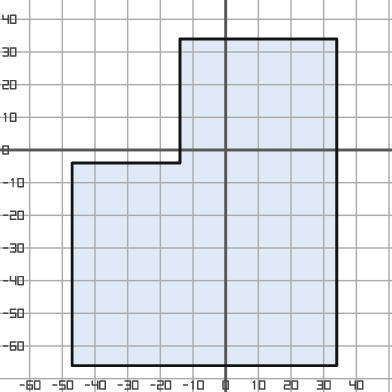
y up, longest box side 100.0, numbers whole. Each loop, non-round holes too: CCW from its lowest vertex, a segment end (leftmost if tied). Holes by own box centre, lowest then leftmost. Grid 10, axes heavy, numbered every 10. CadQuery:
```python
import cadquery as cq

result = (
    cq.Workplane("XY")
    .moveTo(-47.0, -66.0)
    .lineTo(34.0, -66.0)
    .lineTo(34.0, 34.0)
    .lineTo(-14.0, 34.0)
    .lineTo(-14.0, -4.0)
    .lineTo(-47.0, -4.0)
    .close()
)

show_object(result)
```